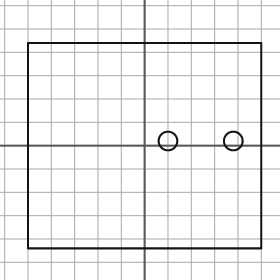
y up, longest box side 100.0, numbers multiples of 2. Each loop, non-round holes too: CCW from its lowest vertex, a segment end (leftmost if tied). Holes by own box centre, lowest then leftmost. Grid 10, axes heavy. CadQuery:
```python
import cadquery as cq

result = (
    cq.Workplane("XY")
    .moveTo(-50.0, -44.0)
    .lineTo(50.0, -44.0)
    .lineTo(50.0, 44.0)
    .lineTo(-50.0, 44.0)
    .close()
    .moveTo(10.0, 2.0)
    .circle(4.0)
    .moveTo(38.0, 2.0)
    .circle(4.0)
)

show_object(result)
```